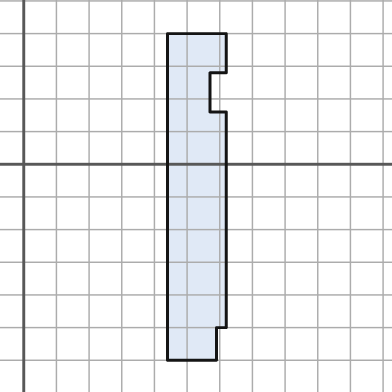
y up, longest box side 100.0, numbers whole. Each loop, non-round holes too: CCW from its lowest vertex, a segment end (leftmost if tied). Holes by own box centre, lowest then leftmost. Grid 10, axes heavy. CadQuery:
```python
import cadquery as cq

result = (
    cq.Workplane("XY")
    .moveTo(44.0, -60.0)
    .lineTo(59.0, -60.0)
    .lineTo(59.0, -50.0)
    .lineTo(62.0, -50.0)
    .lineTo(62.0, 16.0)
    .lineTo(57.0, 16.0)
    .lineTo(57.0, 28.0)
    .lineTo(62.0, 28.0)
    .lineTo(62.0, 40.0)
    .lineTo(44.0, 40.0)
    .close()
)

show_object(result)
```